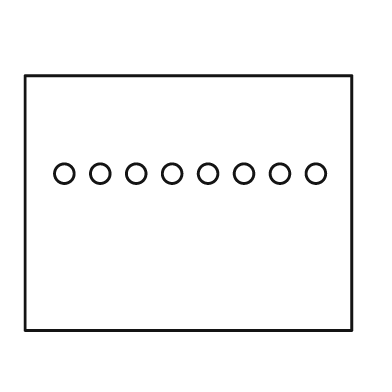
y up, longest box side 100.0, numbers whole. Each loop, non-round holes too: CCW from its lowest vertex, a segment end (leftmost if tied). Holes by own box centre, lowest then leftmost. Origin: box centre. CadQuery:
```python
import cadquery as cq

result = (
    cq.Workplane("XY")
    .moveTo(-50.0, -39.0)
    .lineTo(50.0, -39.0)
    .lineTo(50.0, 39.0)
    .lineTo(-50.0, 39.0)
    .close()
    .moveTo(-38.0, 9.0)
    .circle(3.0)
    .moveTo(-27.0, 9.0)
    .circle(3.0)
    .moveTo(-16.0, 9.0)
    .circle(3.0)
    .moveTo(-5.0, 9.0)
    .circle(3.0)
    .moveTo(6.0, 9.0)
    .circle(3.0)
    .moveTo(17.0, 9.0)
    .circle(3.0)
    .moveTo(28.0, 9.0)
    .circle(3.0)
    .moveTo(39.0, 9.0)
    .circle(3.0)
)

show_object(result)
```